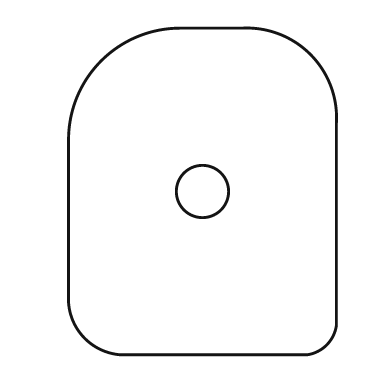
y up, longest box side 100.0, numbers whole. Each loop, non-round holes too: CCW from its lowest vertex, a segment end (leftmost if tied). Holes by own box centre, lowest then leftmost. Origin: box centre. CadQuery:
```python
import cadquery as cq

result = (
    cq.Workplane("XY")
    .moveTo(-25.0, -50.0)
    .lineTo(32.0, -50.0)
    .threePointArc((38.0, -47.0), (41.0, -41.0))
    .lineTo(41.0, 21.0)
    .threePointArc((33.0, 42.0), (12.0, 50.0))
    .lineTo(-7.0, 50.0)
    .threePointArc((-31.0, 40.0), (-41.0, 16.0))
    .lineTo(-41.0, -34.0)
    .threePointArc((-36.0, -45.0), (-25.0, -50.0))
    .close()
    .moveTo(0.0, 0.0)
    .circle(8.0)
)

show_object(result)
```